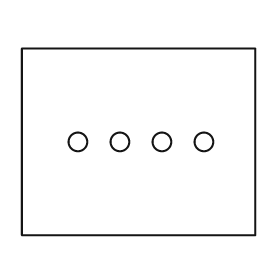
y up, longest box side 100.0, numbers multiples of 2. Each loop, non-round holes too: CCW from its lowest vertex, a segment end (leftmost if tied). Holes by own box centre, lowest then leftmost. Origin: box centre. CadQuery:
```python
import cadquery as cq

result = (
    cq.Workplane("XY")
    .moveTo(-50.0, -40.0)
    .lineTo(50.0, -40.0)
    .lineTo(50.0, 40.0)
    .lineTo(-50.0, 40.0)
    .close()
    .moveTo(-26.0, 0.0)
    .circle(4.0)
    .moveTo(-8.0, 0.0)
    .circle(4.0)
    .moveTo(10.0, 0.0)
    .circle(4.0)
    .moveTo(28.0, 0.0)
    .circle(4.0)
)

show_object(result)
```